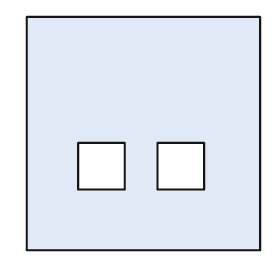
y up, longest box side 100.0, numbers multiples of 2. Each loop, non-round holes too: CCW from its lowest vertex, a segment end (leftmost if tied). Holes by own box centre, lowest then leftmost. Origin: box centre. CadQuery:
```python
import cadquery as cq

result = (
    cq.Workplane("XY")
    .moveTo(-50.0, -50.0)
    .lineTo(50.0, -50.0)
    .lineTo(50.0, 50.0)
    .lineTo(-50.0, 50.0)
    .close()
    .moveTo(-28.0, -24.0)
    .lineTo(-8.0, -24.0)
    .lineTo(-8.0, -4.0)
    .lineTo(-28.0, -4.0)
    .close()
    .moveTo(6.0, -24.0)
    .lineTo(26.0, -24.0)
    .lineTo(26.0, -4.0)
    .lineTo(6.0, -4.0)
    .close()
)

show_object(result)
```